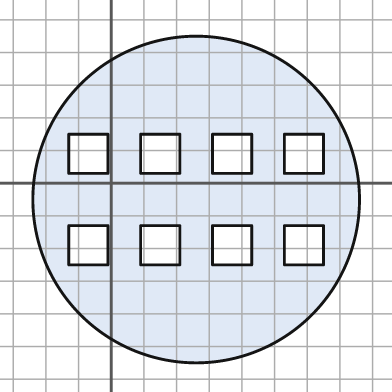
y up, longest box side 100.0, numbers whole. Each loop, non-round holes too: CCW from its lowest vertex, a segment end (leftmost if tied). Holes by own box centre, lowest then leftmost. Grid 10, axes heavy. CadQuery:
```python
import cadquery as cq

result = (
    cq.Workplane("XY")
    .moveTo(26.0, -5.0)
    .circle(50.0)
    .moveTo(-13.0, -25.0)
    .lineTo(-1.0, -25.0)
    .lineTo(-1.0, -13.0)
    .lineTo(-13.0, -13.0)
    .close()
    .moveTo(9.0, -25.0)
    .lineTo(21.0, -25.0)
    .lineTo(21.0, -13.0)
    .lineTo(9.0, -13.0)
    .close()
    .moveTo(31.0, -25.0)
    .lineTo(43.0, -25.0)
    .lineTo(43.0, -13.0)
    .lineTo(31.0, -13.0)
    .close()
    .moveTo(53.0, -25.0)
    .lineTo(65.0, -25.0)
    .lineTo(65.0, -13.0)
    .lineTo(53.0, -13.0)
    .close()
    .moveTo(-13.0, 3.0)
    .lineTo(-1.0, 3.0)
    .lineTo(-1.0, 15.0)
    .lineTo(-13.0, 15.0)
    .close()
    .moveTo(9.0, 3.0)
    .lineTo(21.0, 3.0)
    .lineTo(21.0, 15.0)
    .lineTo(9.0, 15.0)
    .close()
    .moveTo(31.0, 3.0)
    .lineTo(43.0, 3.0)
    .lineTo(43.0, 15.0)
    .lineTo(31.0, 15.0)
    .close()
    .moveTo(53.0, 3.0)
    .lineTo(65.0, 3.0)
    .lineTo(65.0, 15.0)
    .lineTo(53.0, 15.0)
    .close()
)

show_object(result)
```